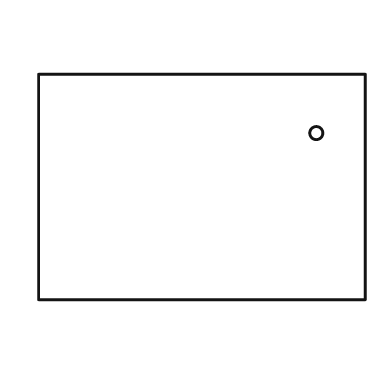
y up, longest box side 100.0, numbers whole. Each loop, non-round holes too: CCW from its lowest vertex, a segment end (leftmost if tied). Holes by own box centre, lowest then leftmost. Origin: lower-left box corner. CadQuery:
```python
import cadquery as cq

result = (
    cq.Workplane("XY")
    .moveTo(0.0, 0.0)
    .lineTo(100.0, 0.0)
    .lineTo(100.0, 69.0)
    .lineTo(0.0, 69.0)
    .close()
    .moveTo(85.0, 51.0)
    .circle(2.0)
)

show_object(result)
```